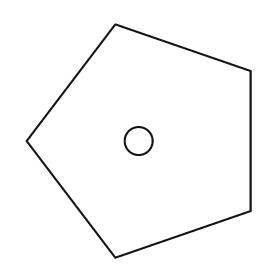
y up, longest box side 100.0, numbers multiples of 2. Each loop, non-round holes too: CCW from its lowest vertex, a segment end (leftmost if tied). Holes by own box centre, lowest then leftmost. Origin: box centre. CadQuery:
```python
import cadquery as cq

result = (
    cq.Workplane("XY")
    .moveTo(-10.0, -50.0)
    .lineTo(48.0, -30.0)
    .lineTo(48.0, 30.0)
    .lineTo(-10.0, 50.0)
    .lineTo(-48.0, 0.0)
    .close()
    .moveTo(0.0, 0.0)
    .circle(6.0)
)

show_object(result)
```